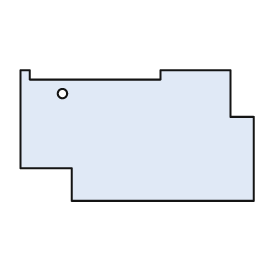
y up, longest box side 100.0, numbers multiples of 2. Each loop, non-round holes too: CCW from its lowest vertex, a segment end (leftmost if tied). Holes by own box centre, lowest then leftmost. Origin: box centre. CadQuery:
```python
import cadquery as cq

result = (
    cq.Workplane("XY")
    .moveTo(-28.0, -28.0)
    .lineTo(50.0, -28.0)
    .lineTo(50.0, 8.0)
    .lineTo(40.0, 8.0)
    .lineTo(40.0, 28.0)
    .lineTo(10.0, 28.0)
    .lineTo(10.0, 24.0)
    .lineTo(-46.0, 24.0)
    .lineTo(-46.0, 28.0)
    .lineTo(-50.0, 28.0)
    .lineTo(-50.0, -14.0)
    .lineTo(-28.0, -14.0)
    .close()
    .moveTo(-32.0, 18.0)
    .circle(2.0)
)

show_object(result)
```